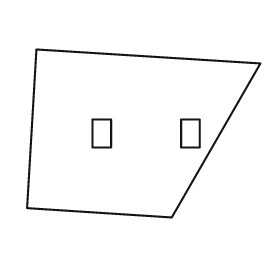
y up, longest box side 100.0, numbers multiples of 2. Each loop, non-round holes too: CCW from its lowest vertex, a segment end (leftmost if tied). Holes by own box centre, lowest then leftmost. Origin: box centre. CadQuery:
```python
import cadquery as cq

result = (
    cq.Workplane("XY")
    .moveTo(12.0, -36.0)
    .lineTo(50.0, 30.0)
    .lineTo(-46.0, 36.0)
    .lineTo(-50.0, -32.0)
    .close()
    .moveTo(-22.0, -6.0)
    .lineTo(-14.0, -6.0)
    .lineTo(-14.0, 6.0)
    .lineTo(-22.0, 6.0)
    .close()
    .moveTo(16.0, -6.0)
    .lineTo(24.0, -6.0)
    .lineTo(24.0, 6.0)
    .lineTo(16.0, 6.0)
    .close()
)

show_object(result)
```